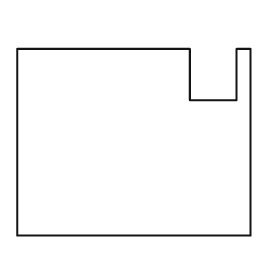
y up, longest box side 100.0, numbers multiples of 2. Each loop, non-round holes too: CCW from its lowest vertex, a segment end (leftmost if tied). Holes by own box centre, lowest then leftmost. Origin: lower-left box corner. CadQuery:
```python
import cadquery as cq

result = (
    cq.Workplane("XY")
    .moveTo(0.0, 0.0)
    .lineTo(100.0, 0.0)
    .lineTo(100.0, 80.0)
    .lineTo(94.0, 80.0)
    .lineTo(94.0, 58.0)
    .lineTo(74.0, 58.0)
    .lineTo(74.0, 80.0)
    .lineTo(0.0, 80.0)
    .close()
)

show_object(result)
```